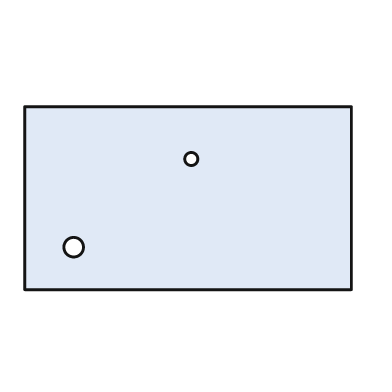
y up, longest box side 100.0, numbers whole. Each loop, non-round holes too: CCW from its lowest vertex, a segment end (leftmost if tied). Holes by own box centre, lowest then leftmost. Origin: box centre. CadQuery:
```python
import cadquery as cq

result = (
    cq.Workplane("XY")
    .moveTo(-50.0, -28.0)
    .lineTo(50.0, -28.0)
    .lineTo(50.0, 28.0)
    .lineTo(-50.0, 28.0)
    .close()
    .moveTo(-35.0, -15.0)
    .circle(3.0)
    .moveTo(1.0, 12.0)
    .circle(2.0)
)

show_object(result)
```